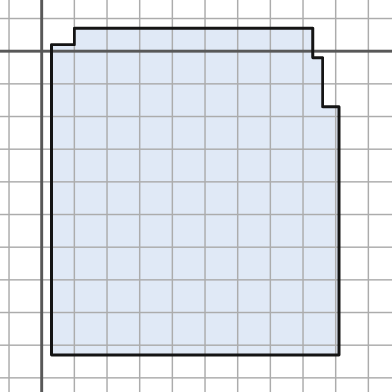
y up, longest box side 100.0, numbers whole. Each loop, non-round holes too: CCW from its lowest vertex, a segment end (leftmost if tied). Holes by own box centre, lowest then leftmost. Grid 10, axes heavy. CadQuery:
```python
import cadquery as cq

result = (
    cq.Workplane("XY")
    .moveTo(3.0, -93.0)
    .lineTo(91.0, -93.0)
    .lineTo(91.0, -17.0)
    .lineTo(86.0, -17.0)
    .lineTo(86.0, -2.0)
    .lineTo(83.0, -2.0)
    .lineTo(83.0, 7.0)
    .lineTo(10.0, 7.0)
    .lineTo(10.0, 2.0)
    .lineTo(3.0, 2.0)
    .close()
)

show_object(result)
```